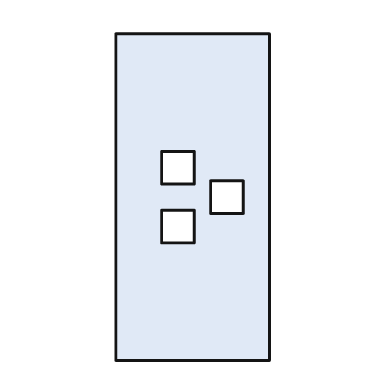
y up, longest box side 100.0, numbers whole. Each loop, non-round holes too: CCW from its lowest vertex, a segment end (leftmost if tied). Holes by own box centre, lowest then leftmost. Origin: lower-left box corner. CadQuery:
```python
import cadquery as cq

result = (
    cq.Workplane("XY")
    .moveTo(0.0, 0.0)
    .lineTo(47.0, 0.0)
    .lineTo(47.0, 100.0)
    .lineTo(0.0, 100.0)
    .close()
    .moveTo(14.0, 36.0)
    .lineTo(24.0, 36.0)
    .lineTo(24.0, 46.0)
    .lineTo(14.0, 46.0)
    .close()
    .moveTo(29.0, 45.0)
    .lineTo(39.0, 45.0)
    .lineTo(39.0, 55.0)
    .lineTo(29.0, 55.0)
    .close()
    .moveTo(14.0, 54.0)
    .lineTo(24.0, 54.0)
    .lineTo(24.0, 64.0)
    .lineTo(14.0, 64.0)
    .close()
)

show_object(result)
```